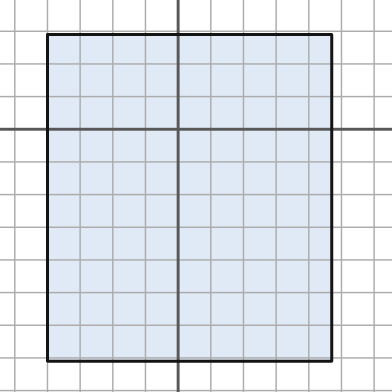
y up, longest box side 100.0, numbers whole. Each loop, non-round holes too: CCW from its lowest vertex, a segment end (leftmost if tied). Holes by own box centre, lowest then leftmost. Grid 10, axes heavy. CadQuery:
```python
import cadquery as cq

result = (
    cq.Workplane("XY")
    .moveTo(-40.0, -71.0)
    .lineTo(47.0, -71.0)
    .lineTo(47.0, 29.0)
    .lineTo(-40.0, 29.0)
    .close()
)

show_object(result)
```